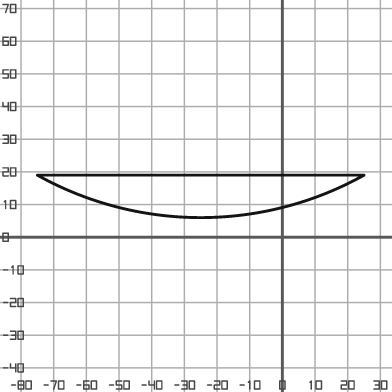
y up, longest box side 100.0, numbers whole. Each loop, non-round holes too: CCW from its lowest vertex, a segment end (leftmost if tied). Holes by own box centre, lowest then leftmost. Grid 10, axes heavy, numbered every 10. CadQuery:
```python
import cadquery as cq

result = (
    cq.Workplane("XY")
    .moveTo(-75.0, 19.0)
    .threePointArc((-25.0, 6.0), (25.0, 19.0))
    .close()
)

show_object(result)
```